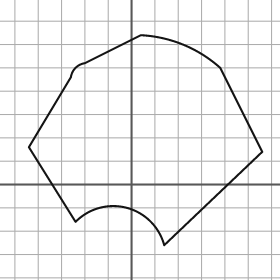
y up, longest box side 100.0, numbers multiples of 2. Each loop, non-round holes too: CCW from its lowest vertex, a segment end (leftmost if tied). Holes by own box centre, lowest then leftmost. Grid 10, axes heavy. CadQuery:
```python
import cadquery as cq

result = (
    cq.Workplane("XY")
    .moveTo(14.0, -26.0)
    .lineTo(56.0, 14.0)
    .lineTo(38.0, 50.0)
    .threePointArc((22.0, 60.0), (4.0, 64.0))
    .lineTo(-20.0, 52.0)
    .threePointArc((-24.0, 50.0), (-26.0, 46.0))
    .lineTo(-44.0, 16.0)
    .lineTo(-24.0, -16.0)
    .threePointArc((-2.0, -10.0), (14.0, -26.0))
    .close()
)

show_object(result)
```